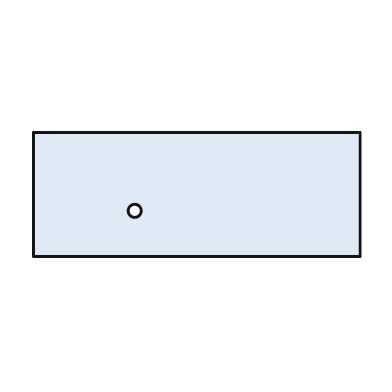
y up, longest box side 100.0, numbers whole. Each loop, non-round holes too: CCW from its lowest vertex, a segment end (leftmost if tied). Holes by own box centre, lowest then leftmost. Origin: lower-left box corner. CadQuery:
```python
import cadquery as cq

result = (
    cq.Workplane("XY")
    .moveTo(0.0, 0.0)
    .lineTo(100.0, 0.0)
    .lineTo(100.0, 38.0)
    .lineTo(0.0, 38.0)
    .close()
    .moveTo(31.0, 14.0)
    .circle(2.0)
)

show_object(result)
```